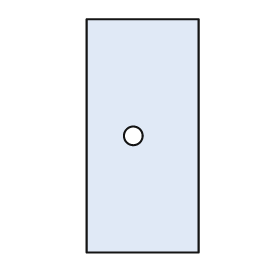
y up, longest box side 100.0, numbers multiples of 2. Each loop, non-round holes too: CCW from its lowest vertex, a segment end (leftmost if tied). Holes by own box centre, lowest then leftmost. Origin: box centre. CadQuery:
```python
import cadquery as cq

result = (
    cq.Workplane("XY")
    .moveTo(-24.0, -50.0)
    .lineTo(24.0, -50.0)
    .lineTo(24.0, 50.0)
    .lineTo(-24.0, 50.0)
    .close()
    .moveTo(-4.0, 0.0)
    .circle(4.0)
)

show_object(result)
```